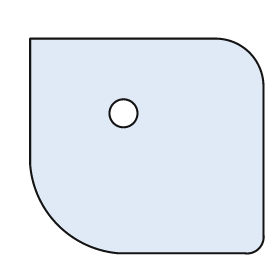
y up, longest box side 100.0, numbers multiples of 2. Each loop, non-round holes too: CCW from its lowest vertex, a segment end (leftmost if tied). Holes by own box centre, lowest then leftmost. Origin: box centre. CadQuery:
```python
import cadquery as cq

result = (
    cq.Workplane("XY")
    .moveTo(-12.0, -46.0)
    .lineTo(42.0, -46.0)
    .threePointArc((48.0, -44.0), (50.0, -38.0))
    .lineTo(50.0, 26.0)
    .threePointArc((44.0, 40.0), (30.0, 46.0))
    .lineTo(-50.0, 46.0)
    .lineTo(-50.0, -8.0)
    .threePointArc((-38.0, -34.0), (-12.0, -46.0))
    .close()
    .moveTo(-10.0, 14.0)
    .circle(6.0)
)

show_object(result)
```